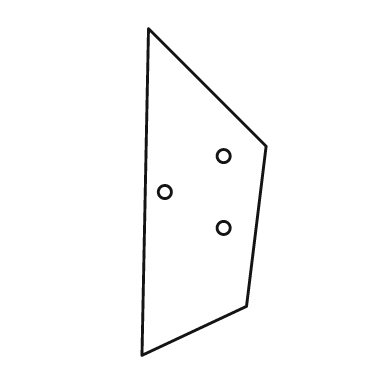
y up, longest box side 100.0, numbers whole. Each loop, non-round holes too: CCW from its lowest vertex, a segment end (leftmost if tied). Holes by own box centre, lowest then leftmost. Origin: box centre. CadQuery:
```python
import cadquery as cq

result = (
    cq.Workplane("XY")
    .moveTo(-19.0, -50.0)
    .lineTo(13.0, -35.0)
    .lineTo(19.0, 14.0)
    .lineTo(-17.0, 50.0)
    .close()
    .moveTo(6.0, -11.0)
    .circle(2.0)
    .moveTo(-12.0, 0.0)
    .circle(2.0)
    .moveTo(6.0, 11.0)
    .circle(2.0)
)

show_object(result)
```